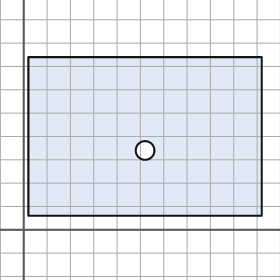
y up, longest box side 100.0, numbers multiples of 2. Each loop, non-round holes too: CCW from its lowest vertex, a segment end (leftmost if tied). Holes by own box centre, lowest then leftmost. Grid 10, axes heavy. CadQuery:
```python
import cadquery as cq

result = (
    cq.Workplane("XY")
    .moveTo(2.0, 6.0)
    .lineTo(102.0, 6.0)
    .lineTo(102.0, 74.0)
    .lineTo(2.0, 74.0)
    .close()
    .moveTo(52.0, 34.0)
    .circle(4.0)
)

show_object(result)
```